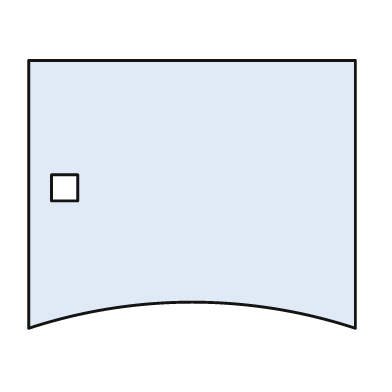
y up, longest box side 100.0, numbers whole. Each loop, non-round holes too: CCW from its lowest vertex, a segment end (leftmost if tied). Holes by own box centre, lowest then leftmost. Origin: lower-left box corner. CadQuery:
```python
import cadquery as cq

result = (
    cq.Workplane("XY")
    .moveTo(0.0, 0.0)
    .threePointArc((50.0, 8.0), (100.0, 0.0))
    .lineTo(100.0, 82.0)
    .lineTo(0.0, 82.0)
    .close()
    .moveTo(7.0, 39.0)
    .lineTo(15.0, 39.0)
    .lineTo(15.0, 47.0)
    .lineTo(7.0, 47.0)
    .close()
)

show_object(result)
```